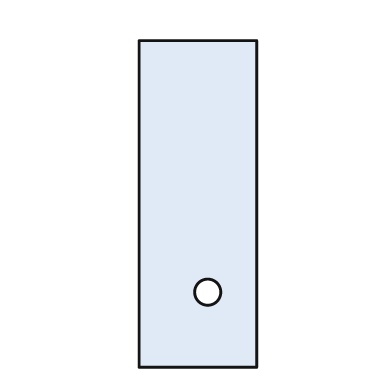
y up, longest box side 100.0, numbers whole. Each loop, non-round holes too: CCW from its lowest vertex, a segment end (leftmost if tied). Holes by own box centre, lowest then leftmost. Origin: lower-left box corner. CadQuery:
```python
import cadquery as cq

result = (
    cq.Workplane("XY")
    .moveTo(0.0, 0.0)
    .lineTo(36.0, 0.0)
    .lineTo(36.0, 100.0)
    .lineTo(0.0, 100.0)
    .close()
    .moveTo(21.0, 23.0)
    .circle(4.0)
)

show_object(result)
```